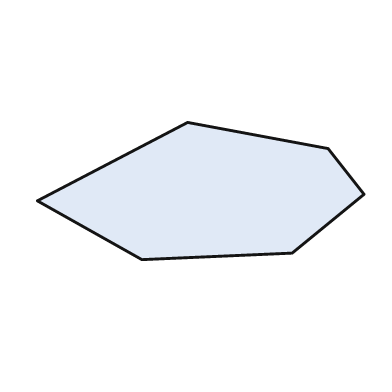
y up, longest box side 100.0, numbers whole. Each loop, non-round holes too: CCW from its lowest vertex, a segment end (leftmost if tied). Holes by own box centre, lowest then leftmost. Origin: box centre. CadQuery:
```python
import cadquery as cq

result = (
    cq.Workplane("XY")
    .moveTo(-18.0, -21.0)
    .lineTo(28.0, -19.0)
    .lineTo(50.0, -1.0)
    .lineTo(39.0, 13.0)
    .lineTo(-4.0, 21.0)
    .lineTo(-50.0, -3.0)
    .close()
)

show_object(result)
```